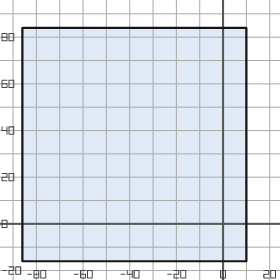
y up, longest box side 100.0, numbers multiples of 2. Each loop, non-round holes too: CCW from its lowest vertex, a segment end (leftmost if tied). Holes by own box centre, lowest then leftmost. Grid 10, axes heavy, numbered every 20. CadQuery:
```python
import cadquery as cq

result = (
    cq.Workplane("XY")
    .moveTo(-86.0, -16.0)
    .lineTo(10.0, -16.0)
    .lineTo(10.0, 84.0)
    .lineTo(-86.0, 84.0)
    .close()
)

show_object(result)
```